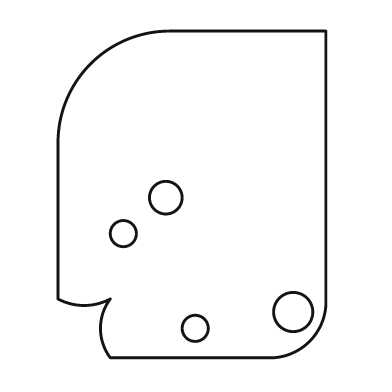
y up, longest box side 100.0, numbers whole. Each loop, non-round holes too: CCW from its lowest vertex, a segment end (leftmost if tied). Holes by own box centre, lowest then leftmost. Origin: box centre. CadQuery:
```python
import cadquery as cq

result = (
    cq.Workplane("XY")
    .moveTo(-25.0, -50.0)
    .lineTo(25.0, -50.0)
    .threePointArc((36.0, -45.0), (41.0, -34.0))
    .lineTo(41.0, 50.0)
    .lineTo(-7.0, 50.0)
    .threePointArc((-31.0, 40.0), (-41.0, 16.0))
    .lineTo(-41.0, -32.0)
    .threePointArc((-33.0, -34.0), (-25.0, -32.0))
    .threePointArc((-28.0, -41.0), (-25.0, -50.0))
    .close()
    .moveTo(1.0, -41.0)
    .circle(4.0)
    .moveTo(31.0, -36.0)
    .circle(6.0)
    .moveTo(-21.0, -12.0)
    .circle(4.0)
    .moveTo(-8.0, -1.0)
    .circle(5.0)
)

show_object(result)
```